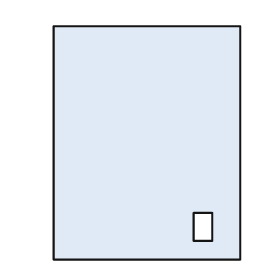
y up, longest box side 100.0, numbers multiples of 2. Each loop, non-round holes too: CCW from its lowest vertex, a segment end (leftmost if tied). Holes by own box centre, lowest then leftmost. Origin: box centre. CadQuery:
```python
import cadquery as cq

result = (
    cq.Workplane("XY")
    .moveTo(-40.0, -50.0)
    .lineTo(40.0, -50.0)
    .lineTo(40.0, 50.0)
    .lineTo(-40.0, 50.0)
    .close()
    .moveTo(20.0, -42.0)
    .lineTo(28.0, -42.0)
    .lineTo(28.0, -30.0)
    .lineTo(20.0, -30.0)
    .close()
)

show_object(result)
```